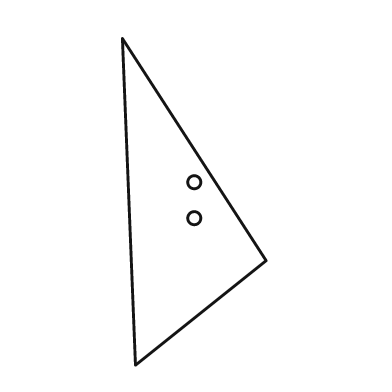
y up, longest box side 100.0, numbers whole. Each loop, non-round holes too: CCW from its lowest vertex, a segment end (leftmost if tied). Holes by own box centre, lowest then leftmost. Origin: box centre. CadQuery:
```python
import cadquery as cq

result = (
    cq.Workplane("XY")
    .moveTo(-18.0, -50.0)
    .lineTo(22.0, -18.0)
    .lineTo(-22.0, 50.0)
    .close()
    .moveTo(0.0, -5.0)
    .circle(2.0)
    .moveTo(0.0, 6.0)
    .circle(2.0)
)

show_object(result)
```